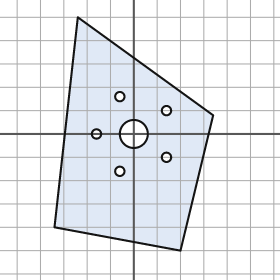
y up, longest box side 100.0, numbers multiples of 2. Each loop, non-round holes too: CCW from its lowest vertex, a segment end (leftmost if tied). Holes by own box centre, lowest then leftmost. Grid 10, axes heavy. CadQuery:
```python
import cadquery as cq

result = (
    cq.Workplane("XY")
    .moveTo(20.0, -50.0)
    .lineTo(34.0, 8.0)
    .lineTo(-24.0, 50.0)
    .lineTo(-34.0, -40.0)
    .close()
    .moveTo(-6.0, -16.0)
    .circle(2.0)
    .moveTo(14.0, -10.0)
    .circle(2.0)
    .moveTo(-16.0, 0.0)
    .circle(2.0)
    .moveTo(0.0, 0.0)
    .circle(6.0)
    .moveTo(14.0, 10.0)
    .circle(2.0)
    .moveTo(-6.0, 16.0)
    .circle(2.0)
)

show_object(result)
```